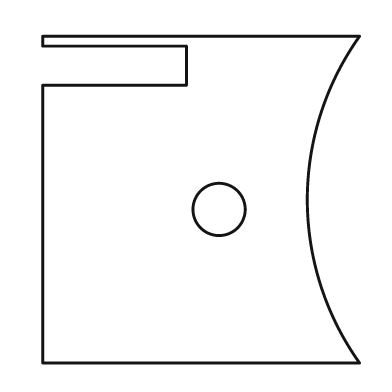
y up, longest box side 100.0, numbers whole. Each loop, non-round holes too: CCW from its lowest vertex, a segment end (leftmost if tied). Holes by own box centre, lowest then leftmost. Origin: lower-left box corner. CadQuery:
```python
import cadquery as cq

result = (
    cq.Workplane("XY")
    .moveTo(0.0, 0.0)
    .lineTo(97.0, 0.0)
    .threePointArc((81.0, 50.0), (97.0, 100.0))
    .lineTo(0.0, 100.0)
    .lineTo(0.0, 97.0)
    .lineTo(44.0, 97.0)
    .lineTo(44.0, 85.0)
    .lineTo(0.0, 85.0)
    .close()
    .moveTo(54.0, 47.0)
    .circle(8.0)
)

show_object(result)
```